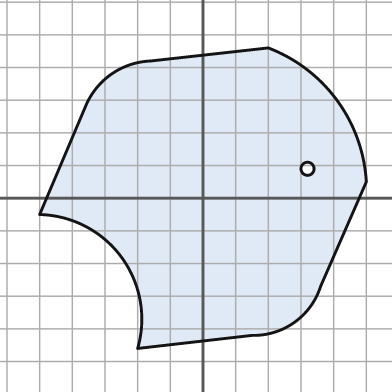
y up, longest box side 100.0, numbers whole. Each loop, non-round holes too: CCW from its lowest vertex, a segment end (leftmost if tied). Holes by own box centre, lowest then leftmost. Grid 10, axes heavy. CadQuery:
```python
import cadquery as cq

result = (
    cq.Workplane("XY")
    .moveTo(-20.0, -46.0)
    .lineTo(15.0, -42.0)
    .threePointArc((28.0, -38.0), (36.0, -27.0))
    .lineTo(50.0, 5.0)
    .threePointArc((41.0, 30.0), (20.0, 46.0))
    .lineTo(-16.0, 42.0)
    .threePointArc((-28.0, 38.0), (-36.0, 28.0))
    .lineTo(-50.0, -5.0)
    .threePointArc((-25.0, -18.0), (-20.0, -46.0))
    .close()
    .moveTo(32.0, 9.0)
    .circle(2.0)
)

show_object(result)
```